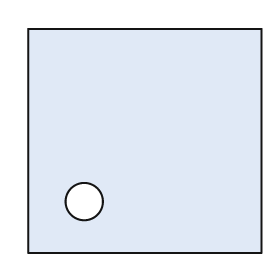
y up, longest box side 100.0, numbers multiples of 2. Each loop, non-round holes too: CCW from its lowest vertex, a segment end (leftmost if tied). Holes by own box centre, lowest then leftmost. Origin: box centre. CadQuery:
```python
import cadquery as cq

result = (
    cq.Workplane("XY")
    .moveTo(-50.0, -48.0)
    .lineTo(50.0, -48.0)
    .lineTo(50.0, 48.0)
    .lineTo(-50.0, 48.0)
    .close()
    .moveTo(-26.0, -26.0)
    .circle(8.0)
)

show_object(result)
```